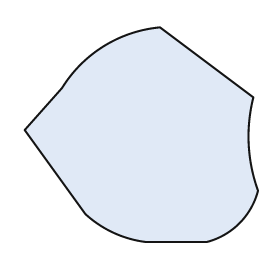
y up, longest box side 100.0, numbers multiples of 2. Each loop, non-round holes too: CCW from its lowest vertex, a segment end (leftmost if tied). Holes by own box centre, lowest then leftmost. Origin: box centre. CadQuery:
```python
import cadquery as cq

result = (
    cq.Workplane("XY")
    .moveTo(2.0, -46.0)
    .lineTo(28.0, -46.0)
    .threePointArc((42.0, -38.0), (50.0, -24.0))
    .threePointArc((46.0, -4.0), (48.0, 16.0))
    .lineTo(8.0, 46.0)
    .threePointArc((-16.0, 38.0), (-34.0, 20.0))
    .lineTo(-50.0, 2.0)
    .lineTo(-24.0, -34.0)
    .threePointArc((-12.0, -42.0), (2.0, -46.0))
    .close()
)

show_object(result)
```